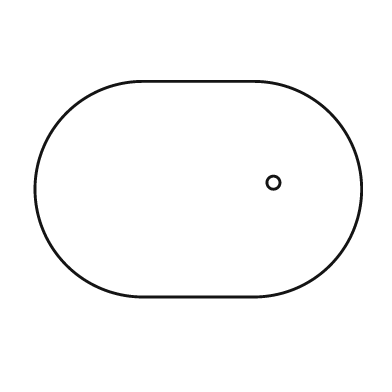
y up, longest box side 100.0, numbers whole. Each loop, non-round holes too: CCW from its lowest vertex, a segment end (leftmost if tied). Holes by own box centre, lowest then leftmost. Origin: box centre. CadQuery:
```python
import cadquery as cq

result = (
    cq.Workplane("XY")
    .moveTo(-17.0, -33.0)
    .lineTo(17.0, -33.0)
    .threePointArc((50.0, 0.0), (17.0, 33.0))
    .lineTo(-17.0, 33.0)
    .threePointArc((-50.0, 0.0), (-17.0, -33.0))
    .close()
    .moveTo(23.0, 2.0)
    .circle(2.0)
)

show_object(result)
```